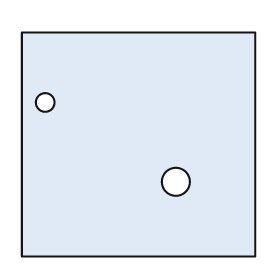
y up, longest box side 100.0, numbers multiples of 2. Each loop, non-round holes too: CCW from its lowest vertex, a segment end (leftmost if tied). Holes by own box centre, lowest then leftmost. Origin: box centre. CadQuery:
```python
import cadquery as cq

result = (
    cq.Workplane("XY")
    .moveTo(-50.0, -48.0)
    .lineTo(50.0, -48.0)
    .lineTo(50.0, 48.0)
    .lineTo(-50.0, 48.0)
    .close()
    .moveTo(16.0, -16.0)
    .circle(6.0)
    .moveTo(-40.0, 18.0)
    .circle(4.0)
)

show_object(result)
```